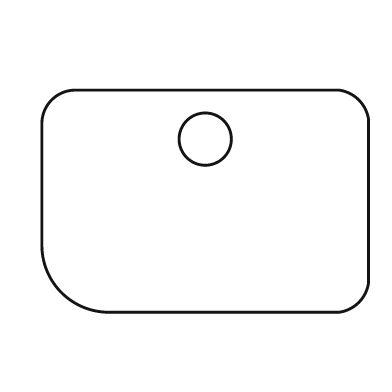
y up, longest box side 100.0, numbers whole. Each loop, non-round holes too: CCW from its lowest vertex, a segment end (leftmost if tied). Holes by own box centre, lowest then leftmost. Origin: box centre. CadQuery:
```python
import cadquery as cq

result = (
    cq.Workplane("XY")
    .moveTo(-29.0, -34.0)
    .lineTo(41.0, -34.0)
    .threePointArc((47.0, -31.0), (50.0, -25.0))
    .lineTo(50.0, 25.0)
    .threePointArc((47.0, 31.0), (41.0, 34.0))
    .lineTo(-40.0, 34.0)
    .threePointArc((-47.0, 31.0), (-50.0, 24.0))
    .lineTo(-50.0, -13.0)
    .threePointArc((-44.0, -28.0), (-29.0, -34.0))
    .close()
    .moveTo(0.0, 19.0)
    .circle(8.0)
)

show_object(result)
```